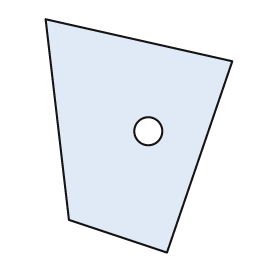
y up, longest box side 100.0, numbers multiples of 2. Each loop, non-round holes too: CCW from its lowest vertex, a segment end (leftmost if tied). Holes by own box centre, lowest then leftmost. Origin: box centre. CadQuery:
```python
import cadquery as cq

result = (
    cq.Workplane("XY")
    .moveTo(12.0, -50.0)
    .lineTo(40.0, 32.0)
    .lineTo(-40.0, 50.0)
    .lineTo(-30.0, -36.0)
    .close()
    .moveTo(4.0, 2.0)
    .circle(6.0)
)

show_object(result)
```